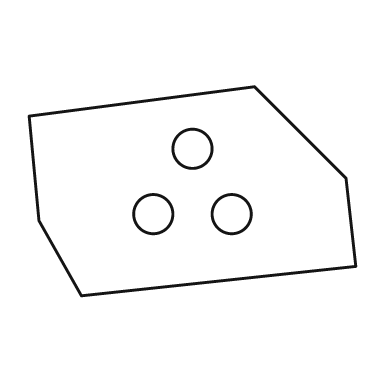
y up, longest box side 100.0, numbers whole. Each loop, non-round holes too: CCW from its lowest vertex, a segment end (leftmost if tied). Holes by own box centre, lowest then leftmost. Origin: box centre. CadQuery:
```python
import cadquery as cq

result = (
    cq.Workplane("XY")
    .moveTo(-34.0, -32.0)
    .lineTo(50.0, -23.0)
    .lineTo(47.0, 4.0)
    .lineTo(19.0, 32.0)
    .lineTo(-50.0, 23.0)
    .lineTo(-47.0, -9.0)
    .close()
    .moveTo(-12.0, -7.0)
    .circle(6.0)
    .moveTo(12.0, -7.0)
    .circle(6.0)
    .moveTo(0.0, 13.0)
    .circle(6.0)
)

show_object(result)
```